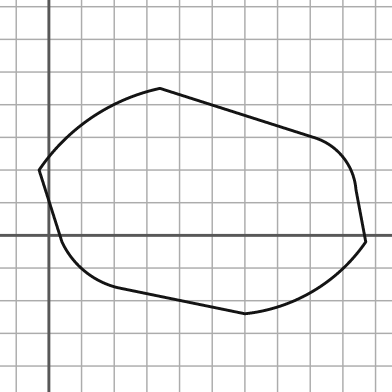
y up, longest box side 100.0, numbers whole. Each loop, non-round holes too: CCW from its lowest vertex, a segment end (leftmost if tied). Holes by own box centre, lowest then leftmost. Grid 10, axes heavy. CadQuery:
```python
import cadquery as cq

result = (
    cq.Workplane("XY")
    .moveTo(60.0, -24.0)
    .threePointArc((81.0, -17.0), (97.0, -2.0))
    .lineTo(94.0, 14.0)
    .threePointArc((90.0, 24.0), (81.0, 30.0))
    .lineTo(34.0, 45.0)
    .threePointArc((13.0, 36.0), (-3.0, 20.0))
    .lineTo(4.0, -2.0)
    .threePointArc((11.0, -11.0), (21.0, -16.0))
    .close()
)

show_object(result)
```